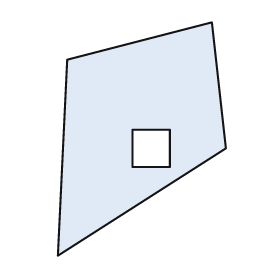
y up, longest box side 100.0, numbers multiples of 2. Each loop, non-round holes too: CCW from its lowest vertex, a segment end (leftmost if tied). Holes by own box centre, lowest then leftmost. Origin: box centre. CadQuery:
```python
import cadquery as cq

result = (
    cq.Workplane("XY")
    .moveTo(-36.0, -50.0)
    .lineTo(36.0, -4.0)
    .lineTo(30.0, 50.0)
    .lineTo(-32.0, 34.0)
    .close()
    .moveTo(-4.0, -12.0)
    .lineTo(12.0, -12.0)
    .lineTo(12.0, 4.0)
    .lineTo(-4.0, 4.0)
    .close()
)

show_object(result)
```